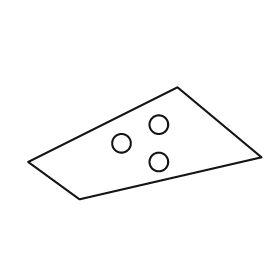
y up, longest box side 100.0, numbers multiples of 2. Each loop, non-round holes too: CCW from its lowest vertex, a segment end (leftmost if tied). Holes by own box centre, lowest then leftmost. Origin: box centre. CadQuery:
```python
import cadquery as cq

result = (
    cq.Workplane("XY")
    .moveTo(-28.0, -24.0)
    .lineTo(50.0, -6.0)
    .lineTo(14.0, 24.0)
    .lineTo(-50.0, -8.0)
    .close()
    .moveTo(6.0, -8.0)
    .circle(4.0)
    .moveTo(-10.0, 0.0)
    .circle(4.0)
    .moveTo(6.0, 8.0)
    .circle(4.0)
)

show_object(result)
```